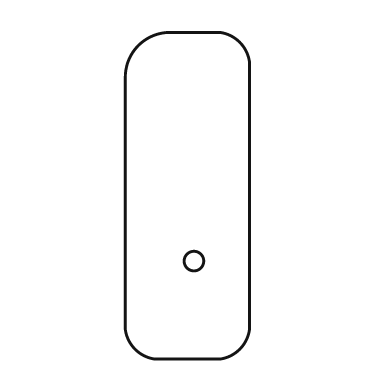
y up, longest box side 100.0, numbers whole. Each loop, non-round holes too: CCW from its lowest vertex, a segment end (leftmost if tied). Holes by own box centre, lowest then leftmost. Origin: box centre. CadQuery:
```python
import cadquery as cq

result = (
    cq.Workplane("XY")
    .moveTo(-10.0, -50.0)
    .lineTo(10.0, -50.0)
    .threePointArc((16.0, -47.0), (19.0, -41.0))
    .lineTo(19.0, 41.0)
    .threePointArc((16.0, 47.0), (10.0, 50.0))
    .lineTo(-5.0, 50.0)
    .threePointArc((-15.0, 46.0), (-19.0, 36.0))
    .lineTo(-19.0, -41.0)
    .threePointArc((-16.0, -47.0), (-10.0, -50.0))
    .close()
    .moveTo(2.0, -20.0)
    .circle(3.0)
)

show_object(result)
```